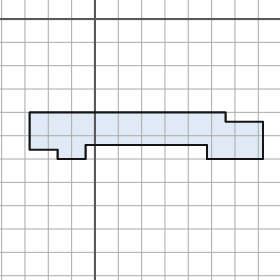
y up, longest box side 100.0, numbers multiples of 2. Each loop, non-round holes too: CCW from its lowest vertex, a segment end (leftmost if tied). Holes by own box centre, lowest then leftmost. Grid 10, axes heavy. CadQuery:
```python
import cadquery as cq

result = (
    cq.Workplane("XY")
    .moveTo(-16.0, -60.0)
    .lineTo(-4.0, -60.0)
    .lineTo(-4.0, -54.0)
    .lineTo(48.0, -54.0)
    .lineTo(48.0, -60.0)
    .lineTo(72.0, -60.0)
    .lineTo(72.0, -44.0)
    .lineTo(56.0, -44.0)
    .lineTo(56.0, -40.0)
    .lineTo(-28.0, -40.0)
    .lineTo(-28.0, -56.0)
    .lineTo(-16.0, -56.0)
    .close()
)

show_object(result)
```